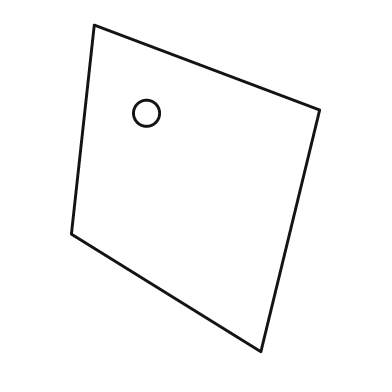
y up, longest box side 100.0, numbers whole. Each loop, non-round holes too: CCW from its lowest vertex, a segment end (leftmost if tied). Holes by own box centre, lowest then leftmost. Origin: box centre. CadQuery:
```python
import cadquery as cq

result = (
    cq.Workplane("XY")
    .moveTo(20.0, -50.0)
    .lineTo(38.0, 24.0)
    .lineTo(-31.0, 50.0)
    .lineTo(-38.0, -14.0)
    .close()
    .moveTo(-15.0, 23.0)
    .circle(4.0)
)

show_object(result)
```